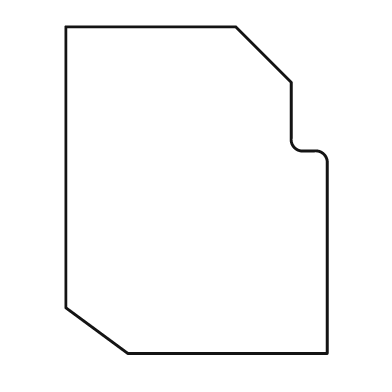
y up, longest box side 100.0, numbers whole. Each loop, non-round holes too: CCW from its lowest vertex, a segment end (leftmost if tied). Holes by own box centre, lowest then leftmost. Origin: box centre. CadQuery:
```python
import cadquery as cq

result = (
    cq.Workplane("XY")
    .moveTo(-21.0, -50.0)
    .lineTo(40.0, -50.0)
    .lineTo(40.0, 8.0)
    .threePointArc((39.0, 11.0), (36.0, 12.0))
    .lineTo(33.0, 12.0)
    .threePointArc((30.0, 13.0), (29.0, 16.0))
    .lineTo(29.0, 33.0)
    .lineTo(12.0, 50.0)
    .lineTo(-40.0, 50.0)
    .lineTo(-40.0, -36.0)
    .close()
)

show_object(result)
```